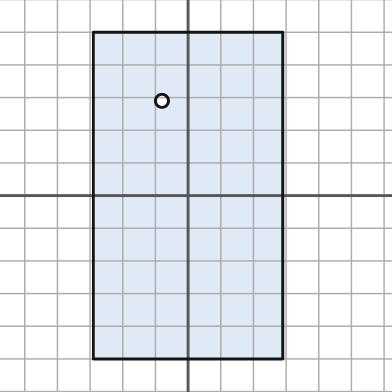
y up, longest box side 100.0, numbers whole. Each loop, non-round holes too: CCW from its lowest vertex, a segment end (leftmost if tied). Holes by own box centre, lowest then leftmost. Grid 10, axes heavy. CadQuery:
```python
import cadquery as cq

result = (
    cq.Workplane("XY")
    .moveTo(-29.0, -50.0)
    .lineTo(29.0, -50.0)
    .lineTo(29.0, 50.0)
    .lineTo(-29.0, 50.0)
    .close()
    .moveTo(-8.0, 29.0)
    .circle(2.0)
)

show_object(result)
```